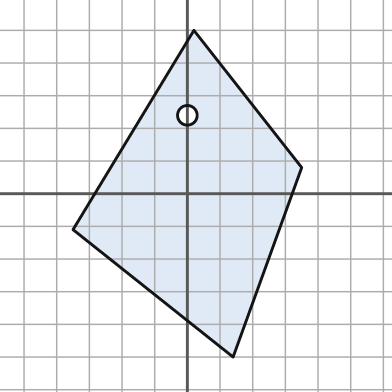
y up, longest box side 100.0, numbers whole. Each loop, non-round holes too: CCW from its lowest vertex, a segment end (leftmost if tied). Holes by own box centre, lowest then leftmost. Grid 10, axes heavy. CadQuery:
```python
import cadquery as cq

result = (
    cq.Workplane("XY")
    .moveTo(14.0, -50.0)
    .lineTo(35.0, 8.0)
    .lineTo(2.0, 50.0)
    .lineTo(-35.0, -11.0)
    .close()
    .moveTo(0.0, 24.0)
    .circle(3.0)
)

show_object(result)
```